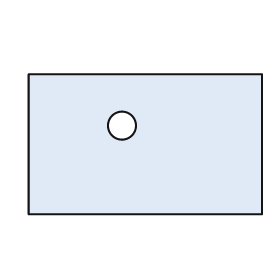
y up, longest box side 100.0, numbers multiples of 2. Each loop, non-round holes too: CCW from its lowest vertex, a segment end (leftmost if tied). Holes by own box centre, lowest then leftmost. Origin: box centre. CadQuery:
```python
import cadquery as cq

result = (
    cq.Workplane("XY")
    .moveTo(-50.0, -30.0)
    .lineTo(50.0, -30.0)
    .lineTo(50.0, 30.0)
    .lineTo(-50.0, 30.0)
    .close()
    .moveTo(-10.0, 8.0)
    .circle(6.0)
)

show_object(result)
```